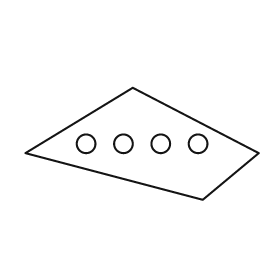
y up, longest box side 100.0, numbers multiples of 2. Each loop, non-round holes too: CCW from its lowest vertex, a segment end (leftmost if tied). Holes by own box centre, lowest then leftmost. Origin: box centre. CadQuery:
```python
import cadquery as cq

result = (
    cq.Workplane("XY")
    .moveTo(26.0, -24.0)
    .lineTo(50.0, -4.0)
    .lineTo(-4.0, 24.0)
    .lineTo(-50.0, -4.0)
    .close()
    .moveTo(-24.0, 0.0)
    .circle(4.0)
    .moveTo(-8.0, 0.0)
    .circle(4.0)
    .moveTo(8.0, 0.0)
    .circle(4.0)
    .moveTo(24.0, 0.0)
    .circle(4.0)
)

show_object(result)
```